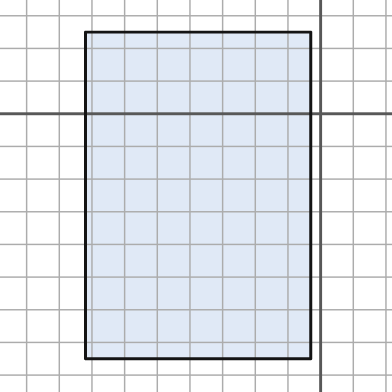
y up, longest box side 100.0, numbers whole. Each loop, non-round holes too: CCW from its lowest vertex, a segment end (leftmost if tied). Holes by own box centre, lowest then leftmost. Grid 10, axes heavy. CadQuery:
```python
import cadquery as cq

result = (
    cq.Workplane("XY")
    .moveTo(-72.0, -75.0)
    .lineTo(-3.0, -75.0)
    .lineTo(-3.0, 25.0)
    .lineTo(-72.0, 25.0)
    .close()
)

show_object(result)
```